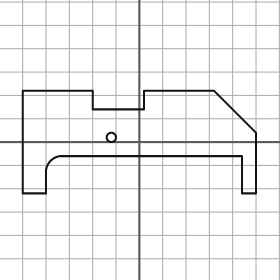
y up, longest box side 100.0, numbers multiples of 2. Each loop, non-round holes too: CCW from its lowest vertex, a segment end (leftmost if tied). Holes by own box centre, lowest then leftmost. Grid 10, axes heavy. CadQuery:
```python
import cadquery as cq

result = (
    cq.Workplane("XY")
    .moveTo(-50.0, -22.0)
    .lineTo(-40.0, -22.0)
    .lineTo(-40.0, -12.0)
    .threePointArc((-38.0, -8.0), (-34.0, -6.0))
    .lineTo(44.0, -6.0)
    .lineTo(44.0, -22.0)
    .lineTo(50.0, -22.0)
    .lineTo(50.0, 4.0)
    .lineTo(32.0, 22.0)
    .lineTo(2.0, 22.0)
    .lineTo(2.0, 14.0)
    .lineTo(-20.0, 14.0)
    .lineTo(-20.0, 22.0)
    .lineTo(-50.0, 22.0)
    .close()
    .moveTo(-12.0, 2.0)
    .circle(2.0)
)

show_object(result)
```